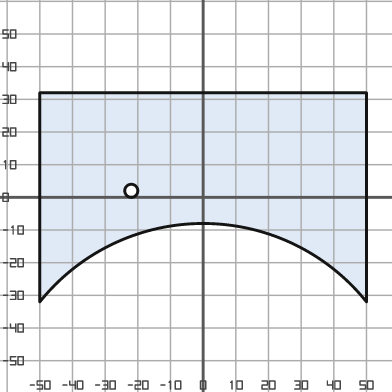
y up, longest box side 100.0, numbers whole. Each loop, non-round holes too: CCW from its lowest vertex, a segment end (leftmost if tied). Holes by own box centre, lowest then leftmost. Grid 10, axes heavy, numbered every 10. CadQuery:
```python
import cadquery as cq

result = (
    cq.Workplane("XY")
    .moveTo(-50.0, -32.0)
    .threePointArc((0.0, -8.0), (50.0, -32.0))
    .lineTo(50.0, 32.0)
    .lineTo(-50.0, 32.0)
    .close()
    .moveTo(-22.0, 2.0)
    .circle(2.0)
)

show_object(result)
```